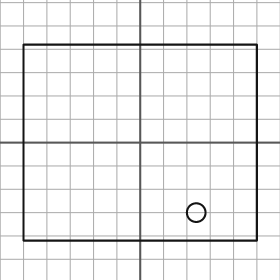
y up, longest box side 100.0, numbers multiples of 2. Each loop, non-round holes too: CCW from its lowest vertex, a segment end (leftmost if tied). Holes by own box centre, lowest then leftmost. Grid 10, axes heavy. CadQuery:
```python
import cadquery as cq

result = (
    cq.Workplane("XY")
    .moveTo(-50.0, -42.0)
    .lineTo(50.0, -42.0)
    .lineTo(50.0, 42.0)
    .lineTo(-50.0, 42.0)
    .close()
    .moveTo(24.0, -30.0)
    .circle(4.0)
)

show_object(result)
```